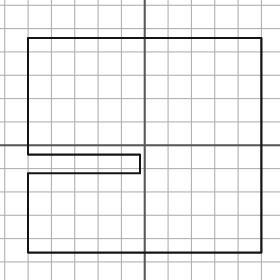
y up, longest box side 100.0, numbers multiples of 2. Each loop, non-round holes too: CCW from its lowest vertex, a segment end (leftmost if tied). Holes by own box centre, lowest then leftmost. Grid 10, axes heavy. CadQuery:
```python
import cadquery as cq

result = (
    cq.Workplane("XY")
    .moveTo(-50.0, -46.0)
    .lineTo(50.0, -46.0)
    .lineTo(50.0, 46.0)
    .lineTo(-50.0, 46.0)
    .lineTo(-50.0, -4.0)
    .lineTo(-2.0, -4.0)
    .lineTo(-2.0, -12.0)
    .lineTo(-50.0, -12.0)
    .close()
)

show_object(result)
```